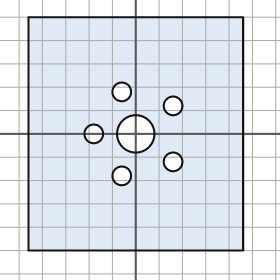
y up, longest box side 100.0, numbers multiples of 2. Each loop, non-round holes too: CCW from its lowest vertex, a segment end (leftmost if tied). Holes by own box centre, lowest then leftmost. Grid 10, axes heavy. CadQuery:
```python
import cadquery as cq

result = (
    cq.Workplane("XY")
    .moveTo(-46.0, -50.0)
    .lineTo(46.0, -50.0)
    .lineTo(46.0, 50.0)
    .lineTo(-46.0, 50.0)
    .close()
    .moveTo(-6.0, -18.0)
    .circle(4.0)
    .moveTo(16.0, -12.0)
    .circle(4.0)
    .moveTo(-18.0, 0.0)
    .circle(4.0)
    .moveTo(0.0, 0.0)
    .circle(8.0)
    .moveTo(16.0, 12.0)
    .circle(4.0)
    .moveTo(-6.0, 18.0)
    .circle(4.0)
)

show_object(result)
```